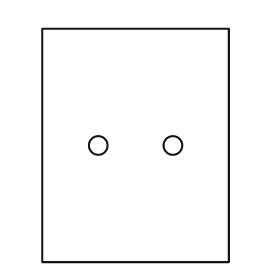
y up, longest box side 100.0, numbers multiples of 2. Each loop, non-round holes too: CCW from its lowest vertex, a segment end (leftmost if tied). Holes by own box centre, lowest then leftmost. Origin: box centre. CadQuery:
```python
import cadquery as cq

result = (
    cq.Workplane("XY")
    .moveTo(-40.0, -50.0)
    .lineTo(40.0, -50.0)
    .lineTo(40.0, 50.0)
    .lineTo(-40.0, 50.0)
    .close()
    .moveTo(-16.0, 0.0)
    .circle(4.0)
    .moveTo(16.0, 0.0)
    .circle(4.0)
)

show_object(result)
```